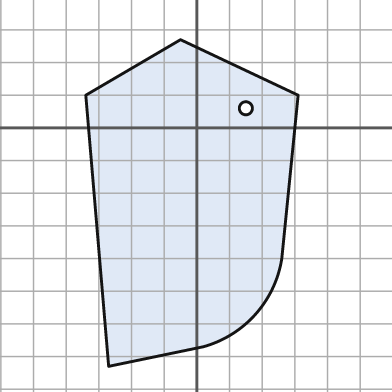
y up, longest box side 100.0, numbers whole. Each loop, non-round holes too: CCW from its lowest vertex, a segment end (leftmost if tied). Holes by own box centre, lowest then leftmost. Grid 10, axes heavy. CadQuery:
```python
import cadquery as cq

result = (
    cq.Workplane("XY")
    .moveTo(-27.0, -73.0)
    .lineTo(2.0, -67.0)
    .threePointArc((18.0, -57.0), (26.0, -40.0))
    .lineTo(31.0, 10.0)
    .lineTo(-5.0, 27.0)
    .lineTo(-34.0, 10.0)
    .close()
    .moveTo(15.0, 6.0)
    .circle(2.0)
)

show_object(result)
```